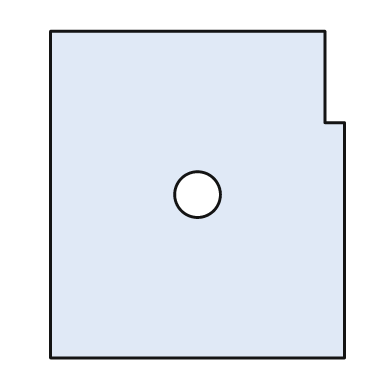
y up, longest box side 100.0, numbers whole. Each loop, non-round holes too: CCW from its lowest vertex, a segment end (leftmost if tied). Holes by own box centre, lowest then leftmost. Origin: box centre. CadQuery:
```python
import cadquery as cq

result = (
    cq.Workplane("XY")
    .moveTo(-45.0, -50.0)
    .lineTo(45.0, -50.0)
    .lineTo(45.0, 22.0)
    .lineTo(39.0, 22.0)
    .lineTo(39.0, 50.0)
    .lineTo(-45.0, 50.0)
    .close()
    .moveTo(0.0, 0.0)
    .circle(7.0)
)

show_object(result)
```